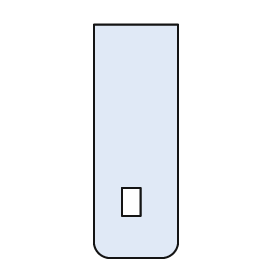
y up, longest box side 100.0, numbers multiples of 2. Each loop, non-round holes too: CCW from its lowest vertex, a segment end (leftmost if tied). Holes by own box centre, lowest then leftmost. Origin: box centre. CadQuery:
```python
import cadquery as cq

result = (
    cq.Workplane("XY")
    .moveTo(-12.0, -50.0)
    .lineTo(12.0, -50.0)
    .threePointArc((16.0, -48.0), (18.0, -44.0))
    .lineTo(18.0, 50.0)
    .lineTo(-18.0, 50.0)
    .lineTo(-18.0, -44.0)
    .threePointArc((-16.0, -48.0), (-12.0, -50.0))
    .close()
    .moveTo(-6.0, -32.0)
    .lineTo(2.0, -32.0)
    .lineTo(2.0, -20.0)
    .lineTo(-6.0, -20.0)
    .close()
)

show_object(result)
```